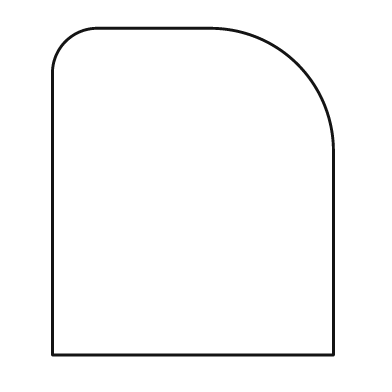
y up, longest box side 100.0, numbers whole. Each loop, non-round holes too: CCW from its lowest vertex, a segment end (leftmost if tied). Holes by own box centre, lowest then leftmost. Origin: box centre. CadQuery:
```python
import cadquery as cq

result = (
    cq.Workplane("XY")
    .moveTo(-43.0, -50.0)
    .lineTo(43.0, -50.0)
    .lineTo(43.0, 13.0)
    .threePointArc((32.0, 39.0), (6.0, 50.0))
    .lineTo(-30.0, 50.0)
    .threePointArc((-39.0, 46.0), (-43.0, 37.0))
    .close()
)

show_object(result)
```